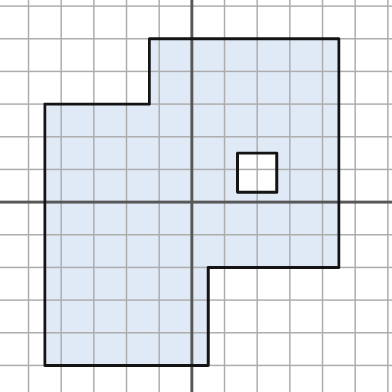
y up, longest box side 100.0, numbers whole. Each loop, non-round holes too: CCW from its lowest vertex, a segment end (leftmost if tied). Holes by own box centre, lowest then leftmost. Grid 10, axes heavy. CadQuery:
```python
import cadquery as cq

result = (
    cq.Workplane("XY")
    .moveTo(-45.0, -50.0)
    .lineTo(5.0, -50.0)
    .lineTo(5.0, -20.0)
    .lineTo(45.0, -20.0)
    .lineTo(45.0, 50.0)
    .lineTo(-13.0, 50.0)
    .lineTo(-13.0, 30.0)
    .lineTo(-45.0, 30.0)
    .close()
    .moveTo(14.0, 3.0)
    .lineTo(26.0, 3.0)
    .lineTo(26.0, 15.0)
    .lineTo(14.0, 15.0)
    .close()
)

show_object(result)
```